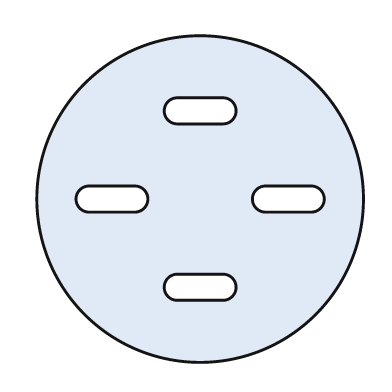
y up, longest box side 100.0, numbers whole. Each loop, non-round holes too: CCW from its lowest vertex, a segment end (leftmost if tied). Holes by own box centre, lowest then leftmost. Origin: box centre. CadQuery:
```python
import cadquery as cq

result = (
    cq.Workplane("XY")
    .moveTo(0.0, 0.0)
    .circle(50.0)
    .moveTo(-7.0, -31.0)
    .lineTo(7.0, -31.0)
    .threePointArc((11.0, -27.0), (7.0, -23.0))
    .lineTo(-7.0, -23.0)
    .threePointArc((-11.0, -27.0), (-7.0, -31.0))
    .close()
    .moveTo(-34.0, -4.0)
    .lineTo(-20.0, -4.0)
    .threePointArc((-16.0, 0.0), (-20.0, 4.0))
    .lineTo(-34.0, 4.0)
    .threePointArc((-38.0, 0.0), (-34.0, -4.0))
    .close()
    .moveTo(20.0, -4.0)
    .lineTo(34.0, -4.0)
    .threePointArc((38.0, 0.0), (34.0, 4.0))
    .lineTo(20.0, 4.0)
    .threePointArc((16.0, 0.0), (20.0, -4.0))
    .close()
    .moveTo(-7.0, 23.0)
    .lineTo(7.0, 23.0)
    .threePointArc((11.0, 27.0), (7.0, 31.0))
    .lineTo(-7.0, 31.0)
    .threePointArc((-11.0, 27.0), (-7.0, 23.0))
    .close()
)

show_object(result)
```